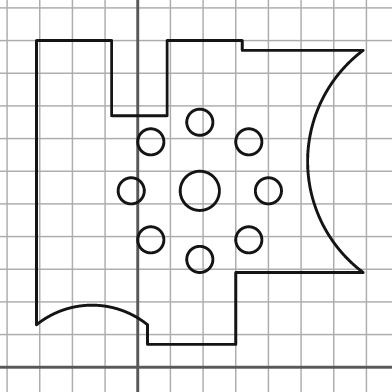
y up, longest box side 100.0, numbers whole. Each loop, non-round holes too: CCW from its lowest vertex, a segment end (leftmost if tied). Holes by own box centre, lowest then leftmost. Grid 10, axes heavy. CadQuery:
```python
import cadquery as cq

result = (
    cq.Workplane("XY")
    .moveTo(3.0, 7.0)
    .lineTo(30.0, 7.0)
    .lineTo(30.0, 29.0)
    .lineTo(69.0, 29.0)
    .threePointArc((52.0, 63.0), (69.0, 97.0))
    .lineTo(32.0, 97.0)
    .lineTo(32.0, 100.0)
    .lineTo(9.0, 100.0)
    .lineTo(9.0, 77.0)
    .lineTo(-8.0, 77.0)
    .lineTo(-8.0, 100.0)
    .lineTo(-31.0, 100.0)
    .lineTo(-31.0, 13.0)
    .threePointArc((-14.0, 19.0), (3.0, 13.0))
    .close()
    .moveTo(19.0, 33.0)
    .circle(4.0)
    .moveTo(4.0, 39.0)
    .circle(4.0)
    .moveTo(34.0, 39.0)
    .circle(4.0)
    .moveTo(-2.0, 54.0)
    .circle(4.0)
    .moveTo(19.0, 54.0)
    .circle(6.0)
    .moveTo(40.0, 54.0)
    .circle(4.0)
    .moveTo(4.0, 69.0)
    .circle(4.0)
    .moveTo(34.0, 69.0)
    .circle(4.0)
    .moveTo(19.0, 75.0)
    .circle(4.0)
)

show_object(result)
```